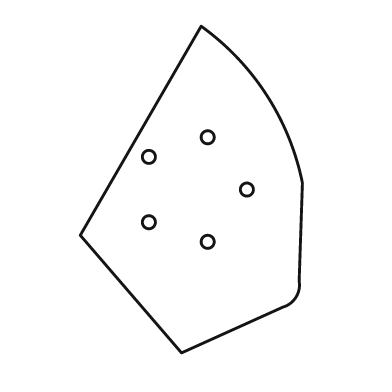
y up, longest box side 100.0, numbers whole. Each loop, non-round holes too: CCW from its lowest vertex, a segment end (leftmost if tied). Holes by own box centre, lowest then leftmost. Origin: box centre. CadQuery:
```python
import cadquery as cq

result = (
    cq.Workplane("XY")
    .moveTo(-3.0, -50.0)
    .lineTo(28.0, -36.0)
    .threePointArc((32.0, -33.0), (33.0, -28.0))
    .lineTo(34.0, 2.0)
    .threePointArc((23.0, 29.0), (3.0, 50.0))
    .lineTo(-34.0, -14.0)
    .close()
    .moveTo(5.0, -16.0)
    .circle(2.0)
    .moveTo(-13.0, -10.0)
    .circle(2.0)
    .moveTo(17.0, 0.0)
    .circle(2.0)
    .moveTo(-13.0, 10.0)
    .circle(2.0)
    .moveTo(5.0, 16.0)
    .circle(2.0)
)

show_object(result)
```